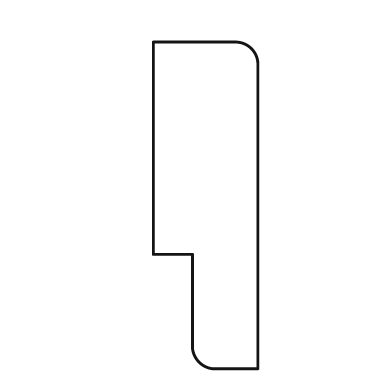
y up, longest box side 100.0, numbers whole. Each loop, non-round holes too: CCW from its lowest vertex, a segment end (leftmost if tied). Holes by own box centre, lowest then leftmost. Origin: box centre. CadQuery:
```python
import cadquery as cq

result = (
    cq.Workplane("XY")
    .moveTo(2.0, -50.0)
    .lineTo(16.0, -50.0)
    .lineTo(16.0, 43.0)
    .threePointArc((14.0, 48.0), (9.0, 50.0))
    .lineTo(-16.0, 50.0)
    .lineTo(-16.0, -15.0)
    .lineTo(-4.0, -15.0)
    .lineTo(-4.0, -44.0)
    .threePointArc((-2.0, -48.0), (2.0, -50.0))
    .close()
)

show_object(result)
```